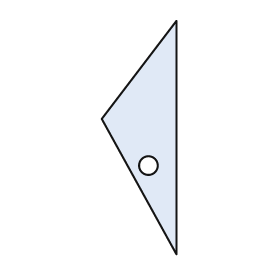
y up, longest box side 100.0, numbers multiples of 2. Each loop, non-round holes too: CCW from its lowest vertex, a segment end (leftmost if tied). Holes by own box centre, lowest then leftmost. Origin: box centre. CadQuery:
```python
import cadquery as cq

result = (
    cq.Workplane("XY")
    .moveTo(16.0, -50.0)
    .lineTo(16.0, 50.0)
    .lineTo(-16.0, 8.0)
    .close()
    .moveTo(4.0, -12.0)
    .circle(4.0)
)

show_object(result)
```